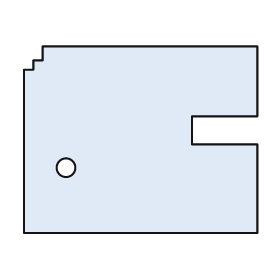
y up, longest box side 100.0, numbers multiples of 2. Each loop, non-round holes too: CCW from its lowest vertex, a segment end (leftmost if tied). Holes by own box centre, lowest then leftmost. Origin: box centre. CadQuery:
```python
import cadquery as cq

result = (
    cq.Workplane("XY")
    .moveTo(-50.0, -40.0)
    .lineTo(50.0, -40.0)
    .lineTo(50.0, -2.0)
    .lineTo(22.0, -2.0)
    .lineTo(22.0, 10.0)
    .lineTo(50.0, 10.0)
    .lineTo(50.0, 40.0)
    .lineTo(-42.0, 40.0)
    .lineTo(-42.0, 34.0)
    .lineTo(-46.0, 34.0)
    .lineTo(-46.0, 30.0)
    .lineTo(-50.0, 30.0)
    .close()
    .moveTo(-32.0, -12.0)
    .circle(4.0)
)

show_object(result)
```